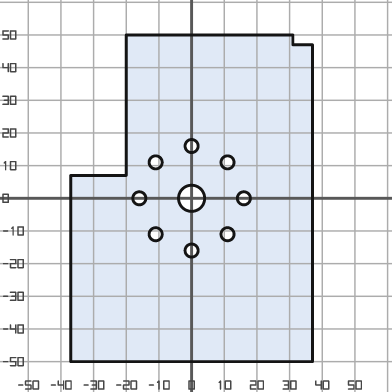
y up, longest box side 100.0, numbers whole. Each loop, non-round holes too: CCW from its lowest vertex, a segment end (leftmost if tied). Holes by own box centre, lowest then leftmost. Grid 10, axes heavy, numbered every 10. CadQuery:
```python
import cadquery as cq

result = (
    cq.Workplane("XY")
    .moveTo(-37.0, -50.0)
    .lineTo(37.0, -50.0)
    .lineTo(37.0, 47.0)
    .lineTo(31.0, 47.0)
    .lineTo(31.0, 50.0)
    .lineTo(-20.0, 50.0)
    .lineTo(-20.0, 7.0)
    .lineTo(-37.0, 7.0)
    .close()
    .moveTo(0.0, -16.0)
    .circle(2.0)
    .moveTo(-11.0, -11.0)
    .circle(2.0)
    .moveTo(11.0, -11.0)
    .circle(2.0)
    .moveTo(-16.0, 0.0)
    .circle(2.0)
    .moveTo(0.0, 0.0)
    .circle(4.0)
    .moveTo(16.0, 0.0)
    .circle(2.0)
    .moveTo(-11.0, 11.0)
    .circle(2.0)
    .moveTo(11.0, 11.0)
    .circle(2.0)
    .moveTo(0.0, 16.0)
    .circle(2.0)
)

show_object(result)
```